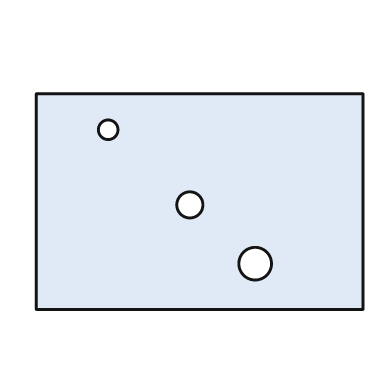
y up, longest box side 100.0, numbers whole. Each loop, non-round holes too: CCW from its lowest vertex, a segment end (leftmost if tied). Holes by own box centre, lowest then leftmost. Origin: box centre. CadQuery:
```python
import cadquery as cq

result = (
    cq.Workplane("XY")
    .moveTo(-50.0, -33.0)
    .lineTo(50.0, -33.0)
    .lineTo(50.0, 33.0)
    .lineTo(-50.0, 33.0)
    .close()
    .moveTo(17.0, -19.0)
    .circle(5.0)
    .moveTo(-3.0, -1.0)
    .circle(4.0)
    .moveTo(-28.0, 22.0)
    .circle(3.0)
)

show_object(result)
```